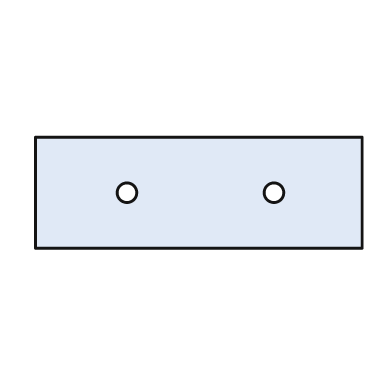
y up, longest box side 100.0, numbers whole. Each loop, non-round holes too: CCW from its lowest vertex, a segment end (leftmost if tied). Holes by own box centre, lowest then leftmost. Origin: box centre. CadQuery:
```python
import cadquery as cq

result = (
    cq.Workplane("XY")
    .moveTo(-50.0, -17.0)
    .lineTo(50.0, -17.0)
    .lineTo(50.0, 17.0)
    .lineTo(-50.0, 17.0)
    .close()
    .moveTo(-22.0, 0.0)
    .circle(3.0)
    .moveTo(23.0, 0.0)
    .circle(3.0)
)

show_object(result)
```